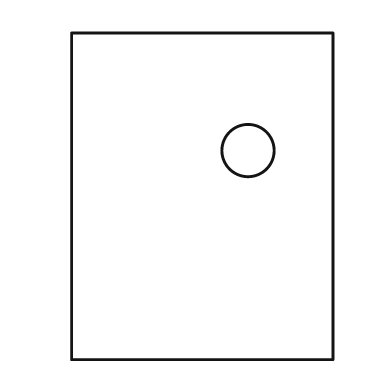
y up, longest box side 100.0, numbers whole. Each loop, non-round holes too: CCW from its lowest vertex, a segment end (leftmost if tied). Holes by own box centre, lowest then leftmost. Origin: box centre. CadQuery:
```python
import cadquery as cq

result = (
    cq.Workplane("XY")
    .moveTo(-40.0, -50.0)
    .lineTo(40.0, -50.0)
    .lineTo(40.0, 50.0)
    .lineTo(-40.0, 50.0)
    .close()
    .moveTo(14.0, 14.0)
    .circle(8.0)
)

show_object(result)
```